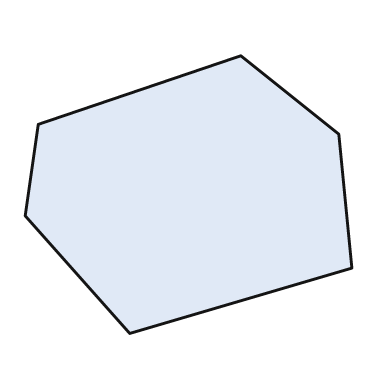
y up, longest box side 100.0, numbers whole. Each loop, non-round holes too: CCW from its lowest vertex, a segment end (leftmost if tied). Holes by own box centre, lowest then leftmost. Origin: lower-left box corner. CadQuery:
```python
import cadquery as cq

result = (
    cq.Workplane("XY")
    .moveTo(32.0, 0.0)
    .lineTo(100.0, 20.0)
    .lineTo(96.0, 61.0)
    .lineTo(66.0, 85.0)
    .lineTo(4.0, 64.0)
    .lineTo(0.0, 36.0)
    .close()
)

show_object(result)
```